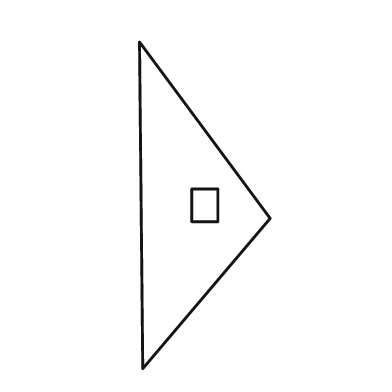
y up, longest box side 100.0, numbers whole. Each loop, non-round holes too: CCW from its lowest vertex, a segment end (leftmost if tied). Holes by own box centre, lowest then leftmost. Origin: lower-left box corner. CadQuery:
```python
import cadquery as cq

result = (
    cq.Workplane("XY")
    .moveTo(1.0, 0.0)
    .lineTo(40.0, 46.0)
    .lineTo(0.0, 100.0)
    .close()
    .moveTo(16.0, 45.0)
    .lineTo(24.0, 45.0)
    .lineTo(24.0, 55.0)
    .lineTo(16.0, 55.0)
    .close()
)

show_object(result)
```